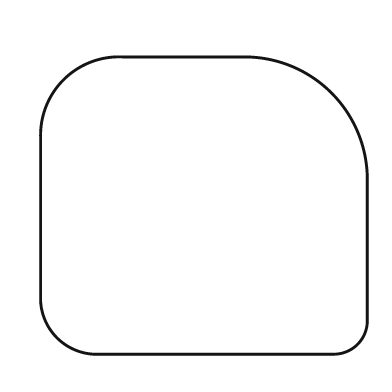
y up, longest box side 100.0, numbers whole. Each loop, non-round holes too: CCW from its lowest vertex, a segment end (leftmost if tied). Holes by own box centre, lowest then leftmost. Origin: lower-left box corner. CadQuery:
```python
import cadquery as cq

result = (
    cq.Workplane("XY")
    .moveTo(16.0, 0.0)
    .lineTo(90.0, 0.0)
    .threePointArc((97.0, 3.0), (100.0, 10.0))
    .lineTo(100.0, 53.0)
    .threePointArc((89.0, 80.0), (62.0, 91.0))
    .lineTo(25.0, 91.0)
    .threePointArc((7.0, 84.0), (0.0, 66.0))
    .lineTo(0.0, 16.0)
    .threePointArc((5.0, 5.0), (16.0, 0.0))
    .close()
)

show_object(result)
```